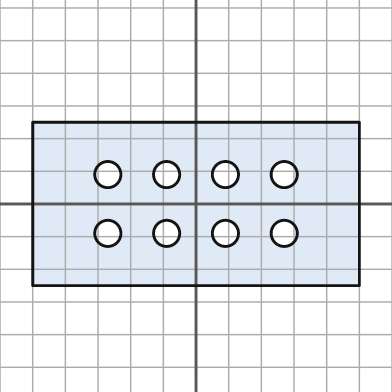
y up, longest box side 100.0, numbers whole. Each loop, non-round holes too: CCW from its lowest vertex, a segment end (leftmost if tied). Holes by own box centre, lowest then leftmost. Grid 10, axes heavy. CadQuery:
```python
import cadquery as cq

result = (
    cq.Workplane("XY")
    .moveTo(-50.0, -25.0)
    .lineTo(50.0, -25.0)
    .lineTo(50.0, 25.0)
    .lineTo(-50.0, 25.0)
    .close()
    .moveTo(-27.0, -9.0)
    .circle(4.0)
    .moveTo(-9.0, -9.0)
    .circle(4.0)
    .moveTo(9.0, -9.0)
    .circle(4.0)
    .moveTo(27.0, -9.0)
    .circle(4.0)
    .moveTo(-27.0, 9.0)
    .circle(4.0)
    .moveTo(-9.0, 9.0)
    .circle(4.0)
    .moveTo(9.0, 9.0)
    .circle(4.0)
    .moveTo(27.0, 9.0)
    .circle(4.0)
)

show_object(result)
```